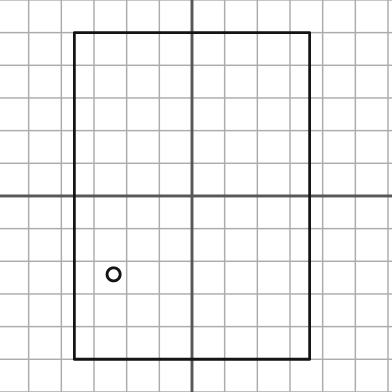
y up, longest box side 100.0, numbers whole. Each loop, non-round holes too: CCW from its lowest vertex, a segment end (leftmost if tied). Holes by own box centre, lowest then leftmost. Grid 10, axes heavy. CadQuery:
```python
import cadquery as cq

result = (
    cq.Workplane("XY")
    .moveTo(-36.0, -50.0)
    .lineTo(36.0, -50.0)
    .lineTo(36.0, 50.0)
    .lineTo(-36.0, 50.0)
    .close()
    .moveTo(-24.0, -24.0)
    .circle(2.0)
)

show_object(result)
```